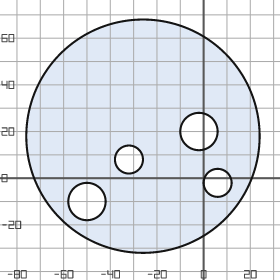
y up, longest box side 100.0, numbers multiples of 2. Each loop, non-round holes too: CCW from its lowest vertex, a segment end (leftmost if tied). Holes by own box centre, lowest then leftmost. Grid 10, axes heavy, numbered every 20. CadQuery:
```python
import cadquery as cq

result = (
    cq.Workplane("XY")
    .moveTo(-26.0, 18.0)
    .circle(50.0)
    .moveTo(-50.0, -10.0)
    .circle(8.0)
    .moveTo(6.0, -2.0)
    .circle(6.0)
    .moveTo(-32.0, 8.0)
    .circle(6.0)
    .moveTo(-2.0, 20.0)
    .circle(8.0)
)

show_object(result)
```